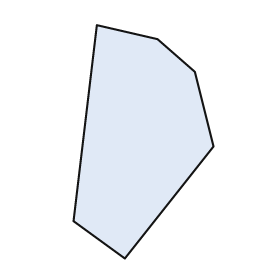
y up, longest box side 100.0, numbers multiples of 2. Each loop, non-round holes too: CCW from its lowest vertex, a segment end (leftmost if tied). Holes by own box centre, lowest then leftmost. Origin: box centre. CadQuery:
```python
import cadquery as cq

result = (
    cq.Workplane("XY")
    .moveTo(-8.0, -50.0)
    .lineTo(30.0, -2.0)
    .lineTo(22.0, 30.0)
    .lineTo(6.0, 44.0)
    .lineTo(-20.0, 50.0)
    .lineTo(-30.0, -34.0)
    .close()
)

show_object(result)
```